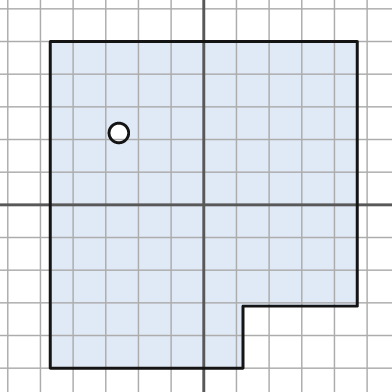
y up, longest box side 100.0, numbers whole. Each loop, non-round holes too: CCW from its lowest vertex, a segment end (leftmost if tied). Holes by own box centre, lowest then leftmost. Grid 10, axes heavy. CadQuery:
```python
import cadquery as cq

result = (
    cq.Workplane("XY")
    .moveTo(-47.0, -50.0)
    .lineTo(12.0, -50.0)
    .lineTo(12.0, -31.0)
    .lineTo(47.0, -31.0)
    .lineTo(47.0, 50.0)
    .lineTo(-47.0, 50.0)
    .close()
    .moveTo(-26.0, 22.0)
    .circle(3.0)
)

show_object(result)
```